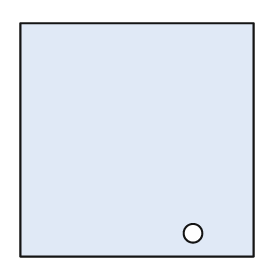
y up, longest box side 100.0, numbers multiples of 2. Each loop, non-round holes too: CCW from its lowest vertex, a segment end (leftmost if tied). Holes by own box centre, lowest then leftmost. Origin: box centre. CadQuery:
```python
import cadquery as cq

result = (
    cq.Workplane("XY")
    .moveTo(-50.0, -50.0)
    .lineTo(50.0, -50.0)
    .lineTo(50.0, 50.0)
    .lineTo(-50.0, 50.0)
    .close()
    .moveTo(24.0, -40.0)
    .circle(4.0)
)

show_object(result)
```